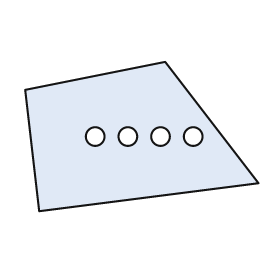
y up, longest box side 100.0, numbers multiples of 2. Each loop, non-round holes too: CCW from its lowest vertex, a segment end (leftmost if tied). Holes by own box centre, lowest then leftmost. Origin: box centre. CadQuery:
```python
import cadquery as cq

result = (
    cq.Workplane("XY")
    .moveTo(-44.0, -32.0)
    .lineTo(50.0, -20.0)
    .lineTo(10.0, 32.0)
    .lineTo(-50.0, 20.0)
    .close()
    .moveTo(-20.0, 0.0)
    .circle(4.0)
    .moveTo(-6.0, 0.0)
    .circle(4.0)
    .moveTo(8.0, 0.0)
    .circle(4.0)
    .moveTo(22.0, 0.0)
    .circle(4.0)
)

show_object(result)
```